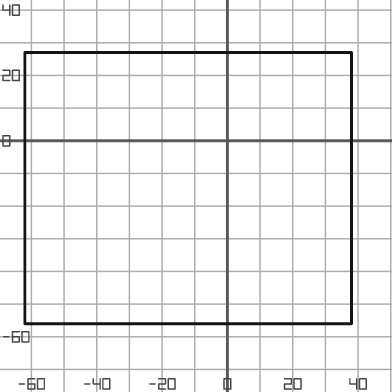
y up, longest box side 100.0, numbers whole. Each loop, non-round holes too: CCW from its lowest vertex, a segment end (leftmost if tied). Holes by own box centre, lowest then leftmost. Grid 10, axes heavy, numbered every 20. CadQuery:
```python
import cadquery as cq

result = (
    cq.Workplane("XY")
    .moveTo(-62.0, -56.0)
    .lineTo(38.0, -56.0)
    .lineTo(38.0, 27.0)
    .lineTo(-62.0, 27.0)
    .close()
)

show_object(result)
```